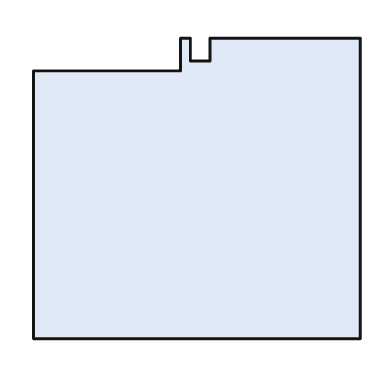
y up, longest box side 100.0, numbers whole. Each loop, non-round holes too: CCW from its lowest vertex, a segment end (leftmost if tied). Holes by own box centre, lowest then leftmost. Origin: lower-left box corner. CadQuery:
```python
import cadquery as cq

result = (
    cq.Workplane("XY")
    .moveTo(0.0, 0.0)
    .lineTo(100.0, 0.0)
    .lineTo(100.0, 92.0)
    .lineTo(54.0, 92.0)
    .lineTo(54.0, 85.0)
    .lineTo(48.0, 85.0)
    .lineTo(48.0, 92.0)
    .lineTo(45.0, 92.0)
    .lineTo(45.0, 82.0)
    .lineTo(0.0, 82.0)
    .close()
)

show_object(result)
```